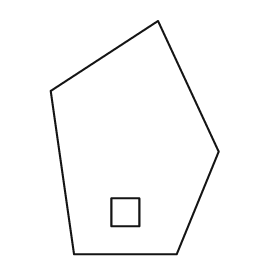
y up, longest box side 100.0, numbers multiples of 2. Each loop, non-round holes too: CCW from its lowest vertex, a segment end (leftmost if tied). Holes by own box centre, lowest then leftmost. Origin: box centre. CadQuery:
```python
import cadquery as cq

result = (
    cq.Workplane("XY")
    .moveTo(-26.0, -50.0)
    .lineTo(18.0, -50.0)
    .lineTo(36.0, -6.0)
    .lineTo(10.0, 50.0)
    .lineTo(-36.0, 20.0)
    .close()
    .moveTo(-10.0, -38.0)
    .lineTo(2.0, -38.0)
    .lineTo(2.0, -26.0)
    .lineTo(-10.0, -26.0)
    .close()
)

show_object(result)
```